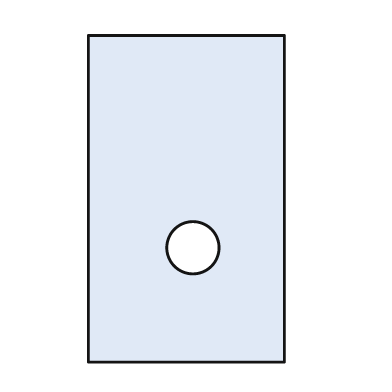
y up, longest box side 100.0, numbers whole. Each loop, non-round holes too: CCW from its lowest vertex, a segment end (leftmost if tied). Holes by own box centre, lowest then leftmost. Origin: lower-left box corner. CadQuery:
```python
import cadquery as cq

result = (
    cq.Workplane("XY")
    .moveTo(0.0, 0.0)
    .lineTo(60.0, 0.0)
    .lineTo(60.0, 100.0)
    .lineTo(0.0, 100.0)
    .close()
    .moveTo(32.0, 35.0)
    .circle(8.0)
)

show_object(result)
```